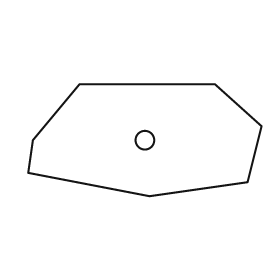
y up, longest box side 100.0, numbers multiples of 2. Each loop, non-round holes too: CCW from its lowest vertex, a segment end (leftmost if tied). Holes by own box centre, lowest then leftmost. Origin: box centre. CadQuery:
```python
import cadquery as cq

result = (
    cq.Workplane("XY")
    .moveTo(2.0, -24.0)
    .lineTo(44.0, -18.0)
    .lineTo(50.0, 6.0)
    .lineTo(30.0, 24.0)
    .lineTo(-28.0, 24.0)
    .lineTo(-48.0, 0.0)
    .lineTo(-50.0, -14.0)
    .close()
    .moveTo(0.0, 0.0)
    .circle(4.0)
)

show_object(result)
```